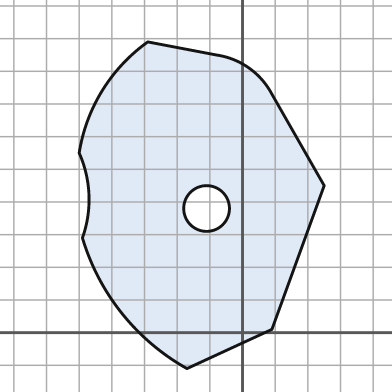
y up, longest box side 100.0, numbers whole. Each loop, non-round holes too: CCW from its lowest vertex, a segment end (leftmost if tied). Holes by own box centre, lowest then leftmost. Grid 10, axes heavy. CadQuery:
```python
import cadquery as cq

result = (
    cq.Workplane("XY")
    .moveTo(-17.0, -11.0)
    .lineTo(9.0, 1.0)
    .lineTo(25.0, 45.0)
    .lineTo(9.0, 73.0)
    .threePointArc((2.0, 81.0), (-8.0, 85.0))
    .lineTo(-29.0, 89.0)
    .threePointArc((-43.0, 74.0), (-50.0, 55.0))
    .threePointArc((-47.0, 42.0), (-49.0, 29.0))
    .threePointArc((-37.0, 6.0), (-17.0, -11.0))
    .close()
    .moveTo(-11.0, 38.0)
    .circle(7.0)
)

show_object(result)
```